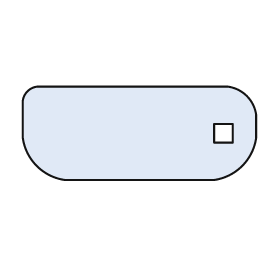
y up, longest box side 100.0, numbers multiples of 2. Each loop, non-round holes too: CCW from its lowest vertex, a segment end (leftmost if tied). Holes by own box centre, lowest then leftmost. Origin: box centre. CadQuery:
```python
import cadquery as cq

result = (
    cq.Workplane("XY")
    .moveTo(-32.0, -20.0)
    .lineTo(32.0, -20.0)
    .threePointArc((44.0, -14.0), (50.0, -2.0))
    .lineTo(50.0, 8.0)
    .threePointArc((46.0, 16.0), (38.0, 20.0))
    .lineTo(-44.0, 20.0)
    .threePointArc((-48.0, 18.0), (-50.0, 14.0))
    .lineTo(-50.0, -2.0)
    .threePointArc((-44.0, -14.0), (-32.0, -20.0))
    .close()
    .moveTo(32.0, -4.0)
    .lineTo(40.0, -4.0)
    .lineTo(40.0, 4.0)
    .lineTo(32.0, 4.0)
    .close()
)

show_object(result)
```